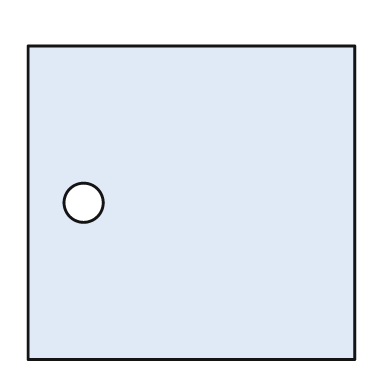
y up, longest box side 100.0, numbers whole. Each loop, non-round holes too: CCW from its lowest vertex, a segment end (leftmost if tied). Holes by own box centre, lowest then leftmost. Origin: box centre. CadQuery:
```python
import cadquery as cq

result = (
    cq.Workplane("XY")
    .moveTo(-50.0, -48.0)
    .lineTo(50.0, -48.0)
    .lineTo(50.0, 48.0)
    .lineTo(-50.0, 48.0)
    .close()
    .moveTo(-33.0, 0.0)
    .circle(6.0)
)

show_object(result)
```